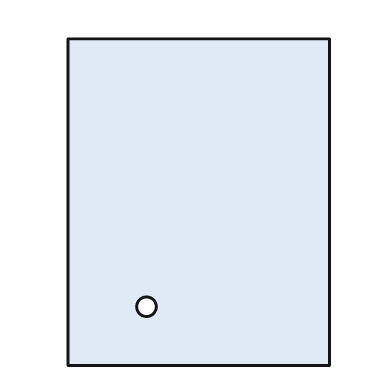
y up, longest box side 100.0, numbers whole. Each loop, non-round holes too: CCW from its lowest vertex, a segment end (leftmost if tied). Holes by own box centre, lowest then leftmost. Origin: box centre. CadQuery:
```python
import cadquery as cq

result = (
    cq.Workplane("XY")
    .moveTo(-40.0, -50.0)
    .lineTo(40.0, -50.0)
    .lineTo(40.0, 50.0)
    .lineTo(-40.0, 50.0)
    .close()
    .moveTo(-16.0, -32.0)
    .circle(3.0)
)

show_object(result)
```